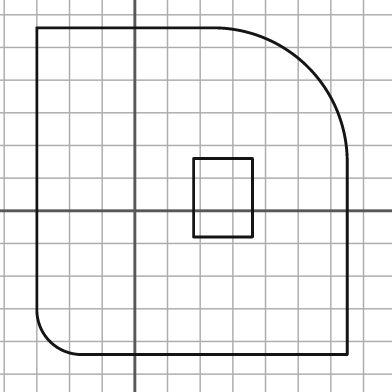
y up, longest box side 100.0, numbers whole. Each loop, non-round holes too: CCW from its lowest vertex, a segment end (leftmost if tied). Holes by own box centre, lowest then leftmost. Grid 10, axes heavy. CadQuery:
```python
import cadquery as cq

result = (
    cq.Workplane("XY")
    .moveTo(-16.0, -44.0)
    .lineTo(65.0, -44.0)
    .lineTo(65.0, 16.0)
    .threePointArc((53.0, 44.0), (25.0, 56.0))
    .lineTo(-30.0, 56.0)
    .lineTo(-30.0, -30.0)
    .threePointArc((-26.0, -40.0), (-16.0, -44.0))
    .close()
    .moveTo(18.0, -8.0)
    .lineTo(36.0, -8.0)
    .lineTo(36.0, 16.0)
    .lineTo(18.0, 16.0)
    .close()
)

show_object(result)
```